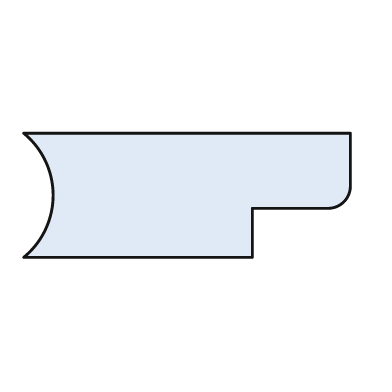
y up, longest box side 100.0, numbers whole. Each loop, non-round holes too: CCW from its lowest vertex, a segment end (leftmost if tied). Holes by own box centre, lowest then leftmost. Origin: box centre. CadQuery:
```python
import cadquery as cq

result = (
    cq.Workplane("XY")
    .moveTo(-50.0, -19.0)
    .lineTo(20.0, -19.0)
    .lineTo(20.0, -4.0)
    .lineTo(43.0, -4.0)
    .threePointArc((48.0, -2.0), (50.0, 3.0))
    .lineTo(50.0, 19.0)
    .lineTo(-50.0, 19.0)
    .threePointArc((-41.0, 0.0), (-50.0, -19.0))
    .close()
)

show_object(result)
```